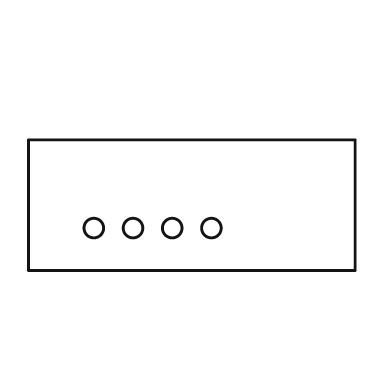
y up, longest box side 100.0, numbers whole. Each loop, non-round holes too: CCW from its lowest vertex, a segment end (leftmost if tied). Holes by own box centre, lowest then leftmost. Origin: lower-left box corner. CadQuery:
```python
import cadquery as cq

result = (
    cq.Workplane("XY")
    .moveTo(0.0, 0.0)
    .lineTo(100.0, 0.0)
    .lineTo(100.0, 40.0)
    .lineTo(0.0, 40.0)
    .close()
    .moveTo(20.0, 13.0)
    .circle(3.0)
    .moveTo(32.0, 13.0)
    .circle(3.0)
    .moveTo(44.0, 13.0)
    .circle(3.0)
    .moveTo(56.0, 13.0)
    .circle(3.0)
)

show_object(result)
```